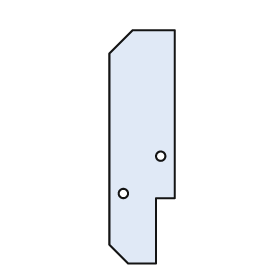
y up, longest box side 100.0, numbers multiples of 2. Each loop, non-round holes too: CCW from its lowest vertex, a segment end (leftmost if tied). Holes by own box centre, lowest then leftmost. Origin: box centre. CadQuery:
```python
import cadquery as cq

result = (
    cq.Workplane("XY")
    .moveTo(-6.0, -50.0)
    .lineTo(6.0, -50.0)
    .lineTo(6.0, -22.0)
    .lineTo(14.0, -22.0)
    .lineTo(14.0, 50.0)
    .lineTo(-4.0, 50.0)
    .lineTo(-14.0, 40.0)
    .lineTo(-14.0, -42.0)
    .close()
    .moveTo(-8.0, -20.0)
    .circle(2.0)
    .moveTo(8.0, -4.0)
    .circle(2.0)
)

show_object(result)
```